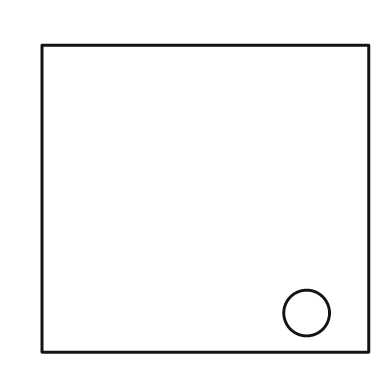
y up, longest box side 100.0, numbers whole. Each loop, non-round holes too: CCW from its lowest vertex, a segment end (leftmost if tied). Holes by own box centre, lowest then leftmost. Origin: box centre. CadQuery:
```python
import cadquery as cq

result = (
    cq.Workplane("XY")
    .moveTo(-50.0, -47.0)
    .lineTo(50.0, -47.0)
    .lineTo(50.0, 47.0)
    .lineTo(-50.0, 47.0)
    .close()
    .moveTo(31.0, -35.0)
    .circle(7.0)
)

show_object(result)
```